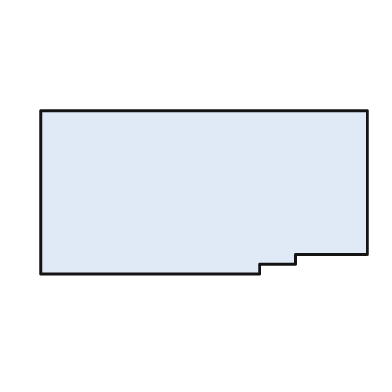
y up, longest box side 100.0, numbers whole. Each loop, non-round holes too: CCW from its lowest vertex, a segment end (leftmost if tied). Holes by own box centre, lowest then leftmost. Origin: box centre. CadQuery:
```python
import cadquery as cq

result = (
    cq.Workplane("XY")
    .moveTo(-50.0, -25.0)
    .lineTo(17.0, -25.0)
    .lineTo(17.0, -22.0)
    .lineTo(28.0, -22.0)
    .lineTo(28.0, -19.0)
    .lineTo(50.0, -19.0)
    .lineTo(50.0, 25.0)
    .lineTo(-50.0, 25.0)
    .close()
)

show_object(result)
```